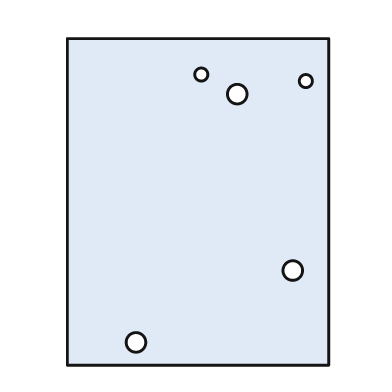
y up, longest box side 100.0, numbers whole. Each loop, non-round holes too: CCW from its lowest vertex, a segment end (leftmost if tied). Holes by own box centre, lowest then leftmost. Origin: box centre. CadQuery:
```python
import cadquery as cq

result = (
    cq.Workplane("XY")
    .moveTo(-40.0, -50.0)
    .lineTo(40.0, -50.0)
    .lineTo(40.0, 50.0)
    .lineTo(-40.0, 50.0)
    .close()
    .moveTo(-19.0, -43.0)
    .circle(3.0)
    .moveTo(29.0, -21.0)
    .circle(3.0)
    .moveTo(12.0, 33.0)
    .circle(3.0)
    .moveTo(33.0, 37.0)
    .circle(2.0)
    .moveTo(1.0, 39.0)
    .circle(2.0)
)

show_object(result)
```